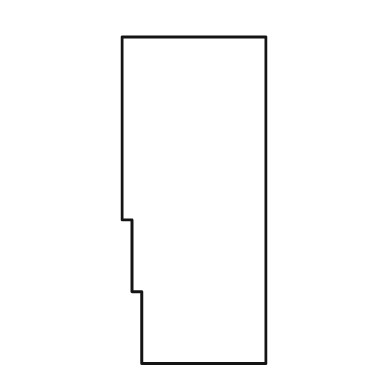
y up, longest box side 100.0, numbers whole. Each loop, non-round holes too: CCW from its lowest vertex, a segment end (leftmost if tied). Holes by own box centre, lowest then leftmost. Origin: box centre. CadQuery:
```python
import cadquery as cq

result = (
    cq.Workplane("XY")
    .moveTo(-16.0, -50.0)
    .lineTo(22.0, -50.0)
    .lineTo(22.0, 50.0)
    .lineTo(-22.0, 50.0)
    .lineTo(-22.0, -6.0)
    .lineTo(-19.0, -6.0)
    .lineTo(-19.0, -28.0)
    .lineTo(-16.0, -28.0)
    .close()
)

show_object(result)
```